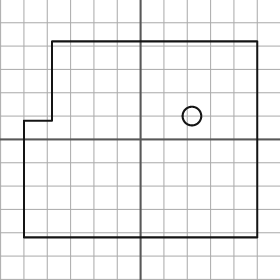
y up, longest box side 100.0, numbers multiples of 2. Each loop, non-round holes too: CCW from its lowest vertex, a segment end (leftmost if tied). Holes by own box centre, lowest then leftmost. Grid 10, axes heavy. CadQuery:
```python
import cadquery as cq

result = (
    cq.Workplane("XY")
    .moveTo(-50.0, -42.0)
    .lineTo(50.0, -42.0)
    .lineTo(50.0, 42.0)
    .lineTo(-38.0, 42.0)
    .lineTo(-38.0, 8.0)
    .lineTo(-50.0, 8.0)
    .close()
    .moveTo(22.0, 10.0)
    .circle(4.0)
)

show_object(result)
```